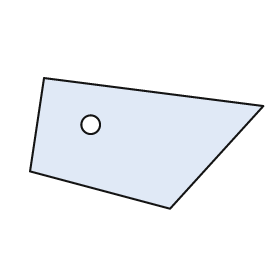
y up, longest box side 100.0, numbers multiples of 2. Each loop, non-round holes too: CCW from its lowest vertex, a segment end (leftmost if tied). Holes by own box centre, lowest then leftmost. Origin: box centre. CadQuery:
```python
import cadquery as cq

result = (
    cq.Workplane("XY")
    .moveTo(10.0, -28.0)
    .lineTo(50.0, 16.0)
    .lineTo(-44.0, 28.0)
    .lineTo(-50.0, -12.0)
    .close()
    .moveTo(-24.0, 8.0)
    .circle(4.0)
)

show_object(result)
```